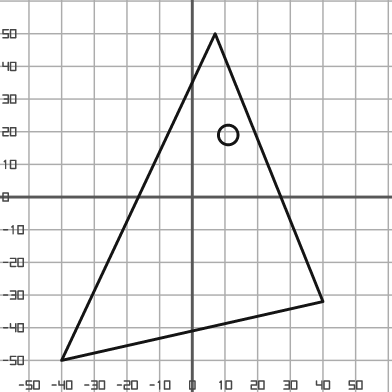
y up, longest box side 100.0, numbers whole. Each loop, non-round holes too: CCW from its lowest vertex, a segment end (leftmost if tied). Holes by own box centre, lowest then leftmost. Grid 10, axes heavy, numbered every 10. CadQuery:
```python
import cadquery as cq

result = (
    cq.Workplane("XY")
    .moveTo(-40.0, -50.0)
    .lineTo(40.0, -32.0)
    .lineTo(7.0, 50.0)
    .close()
    .moveTo(11.0, 19.0)
    .circle(3.0)
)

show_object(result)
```